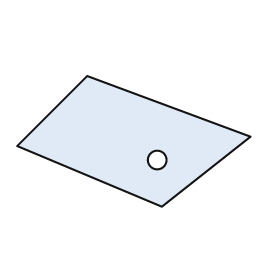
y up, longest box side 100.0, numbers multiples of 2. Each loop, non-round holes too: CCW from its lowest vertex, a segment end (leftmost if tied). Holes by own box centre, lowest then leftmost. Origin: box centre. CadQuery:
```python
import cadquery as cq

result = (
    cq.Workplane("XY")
    .moveTo(12.0, -28.0)
    .lineTo(50.0, 2.0)
    .lineTo(-20.0, 28.0)
    .lineTo(-50.0, -2.0)
    .close()
    .moveTo(10.0, -8.0)
    .circle(4.0)
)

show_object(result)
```